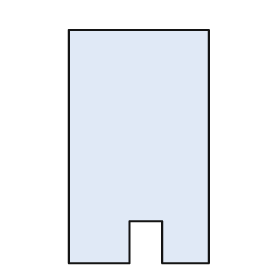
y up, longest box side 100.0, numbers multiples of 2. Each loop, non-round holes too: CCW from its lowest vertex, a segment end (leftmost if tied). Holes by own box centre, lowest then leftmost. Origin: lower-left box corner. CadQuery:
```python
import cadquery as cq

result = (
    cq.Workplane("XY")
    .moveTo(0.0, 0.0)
    .lineTo(26.0, 0.0)
    .lineTo(26.0, 18.0)
    .lineTo(40.0, 18.0)
    .lineTo(40.0, 0.0)
    .lineTo(60.0, 0.0)
    .lineTo(60.0, 100.0)
    .lineTo(0.0, 100.0)
    .close()
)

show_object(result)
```